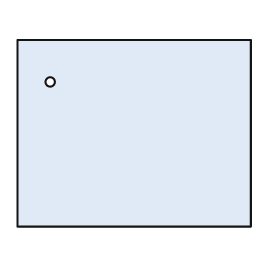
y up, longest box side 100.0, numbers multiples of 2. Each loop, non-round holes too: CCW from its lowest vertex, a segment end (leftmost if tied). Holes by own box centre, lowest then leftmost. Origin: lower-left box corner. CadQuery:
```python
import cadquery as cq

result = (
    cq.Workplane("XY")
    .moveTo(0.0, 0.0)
    .lineTo(100.0, 0.0)
    .lineTo(100.0, 80.0)
    .lineTo(0.0, 80.0)
    .close()
    .moveTo(14.0, 62.0)
    .circle(2.0)
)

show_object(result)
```